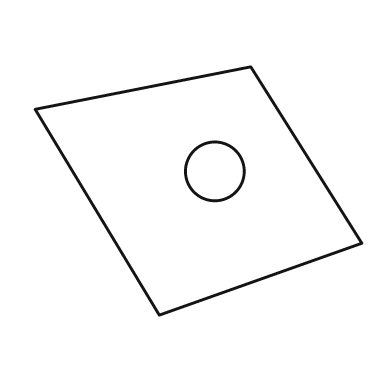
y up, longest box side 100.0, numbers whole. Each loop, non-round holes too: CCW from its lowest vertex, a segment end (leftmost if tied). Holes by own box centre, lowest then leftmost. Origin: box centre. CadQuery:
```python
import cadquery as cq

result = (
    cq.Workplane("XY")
    .moveTo(-12.0, -38.0)
    .lineTo(50.0, -16.0)
    .lineTo(16.0, 38.0)
    .lineTo(-50.0, 25.0)
    .close()
    .moveTo(5.0, 6.0)
    .circle(9.0)
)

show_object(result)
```